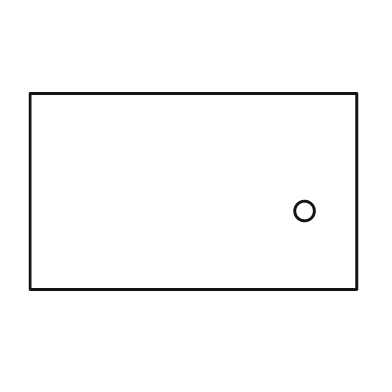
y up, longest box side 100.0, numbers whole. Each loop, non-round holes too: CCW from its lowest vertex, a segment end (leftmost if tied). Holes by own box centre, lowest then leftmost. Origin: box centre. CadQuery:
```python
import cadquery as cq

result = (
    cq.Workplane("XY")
    .moveTo(-50.0, -30.0)
    .lineTo(50.0, -30.0)
    .lineTo(50.0, 30.0)
    .lineTo(-50.0, 30.0)
    .close()
    .moveTo(34.0, -6.0)
    .circle(3.0)
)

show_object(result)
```